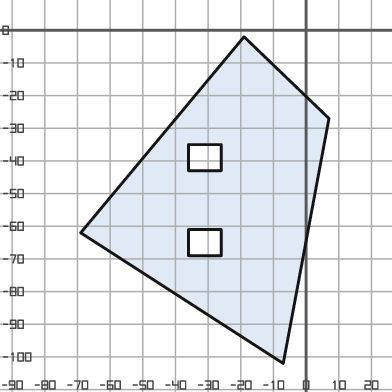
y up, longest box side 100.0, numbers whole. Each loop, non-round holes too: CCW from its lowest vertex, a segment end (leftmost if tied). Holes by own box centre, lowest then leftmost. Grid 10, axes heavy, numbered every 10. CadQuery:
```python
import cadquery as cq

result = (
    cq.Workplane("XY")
    .moveTo(-7.0, -102.0)
    .lineTo(7.0, -27.0)
    .lineTo(-19.0, -2.0)
    .lineTo(-69.0, -62.0)
    .close()
    .moveTo(-36.0, -69.0)
    .lineTo(-26.0, -69.0)
    .lineTo(-26.0, -61.0)
    .lineTo(-36.0, -61.0)
    .close()
    .moveTo(-36.0, -43.0)
    .lineTo(-26.0, -43.0)
    .lineTo(-26.0, -35.0)
    .lineTo(-36.0, -35.0)
    .close()
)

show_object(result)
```